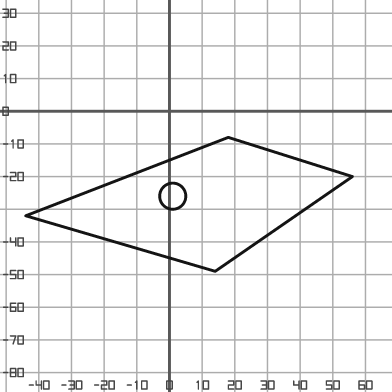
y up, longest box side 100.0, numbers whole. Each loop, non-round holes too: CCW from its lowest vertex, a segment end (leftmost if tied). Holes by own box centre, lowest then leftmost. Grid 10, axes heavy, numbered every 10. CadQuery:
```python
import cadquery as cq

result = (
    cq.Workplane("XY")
    .moveTo(14.0, -49.0)
    .lineTo(56.0, -20.0)
    .lineTo(18.0, -8.0)
    .lineTo(-44.0, -32.0)
    .close()
    .moveTo(1.0, -26.0)
    .circle(4.0)
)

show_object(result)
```